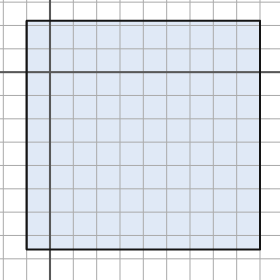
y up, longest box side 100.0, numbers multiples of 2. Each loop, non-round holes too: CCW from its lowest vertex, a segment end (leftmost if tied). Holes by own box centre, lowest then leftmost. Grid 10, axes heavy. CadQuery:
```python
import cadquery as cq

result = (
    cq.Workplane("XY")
    .moveTo(-10.0, -76.0)
    .lineTo(90.0, -76.0)
    .lineTo(90.0, 22.0)
    .lineTo(-10.0, 22.0)
    .close()
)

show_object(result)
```